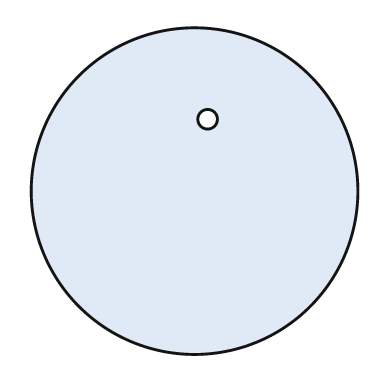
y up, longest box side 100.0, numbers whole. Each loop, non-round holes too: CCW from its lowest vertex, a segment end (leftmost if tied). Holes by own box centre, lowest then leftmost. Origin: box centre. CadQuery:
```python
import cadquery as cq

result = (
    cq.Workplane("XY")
    .moveTo(0.0, 0.0)
    .circle(50.0)
    .moveTo(4.0, 22.0)
    .circle(3.0)
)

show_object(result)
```